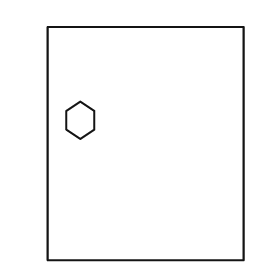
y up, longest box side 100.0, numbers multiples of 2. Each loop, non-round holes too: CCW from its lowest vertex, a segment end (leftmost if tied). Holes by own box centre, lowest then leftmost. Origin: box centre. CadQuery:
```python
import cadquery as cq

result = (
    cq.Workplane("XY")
    .moveTo(-42.0, -50.0)
    .lineTo(42.0, -50.0)
    .lineTo(42.0, 50.0)
    .lineTo(-42.0, 50.0)
    .close()
    .moveTo(-28.0, 2.0)
    .lineTo(-22.0, 6.0)
    .lineTo(-22.0, 14.0)
    .lineTo(-28.0, 18.0)
    .lineTo(-34.0, 14.0)
    .lineTo(-34.0, 6.0)
    .close()
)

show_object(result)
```